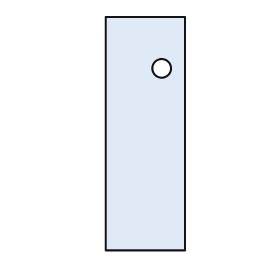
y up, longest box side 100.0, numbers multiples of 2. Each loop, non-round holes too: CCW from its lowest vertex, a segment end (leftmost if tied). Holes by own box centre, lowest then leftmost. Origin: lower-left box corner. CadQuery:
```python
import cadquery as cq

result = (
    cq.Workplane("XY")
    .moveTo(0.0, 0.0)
    .lineTo(34.0, 0.0)
    .lineTo(34.0, 100.0)
    .lineTo(0.0, 100.0)
    .close()
    .moveTo(24.0, 78.0)
    .circle(4.0)
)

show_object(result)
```